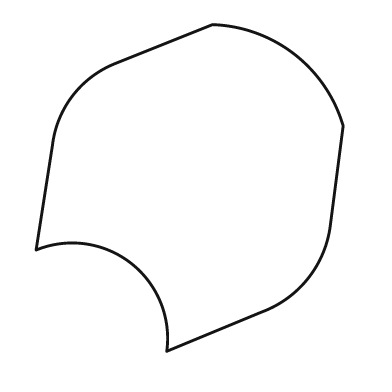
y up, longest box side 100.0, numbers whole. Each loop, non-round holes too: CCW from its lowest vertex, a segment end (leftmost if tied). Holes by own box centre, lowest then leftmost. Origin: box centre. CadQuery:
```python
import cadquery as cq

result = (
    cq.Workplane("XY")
    .moveTo(-7.0, -50.0)
    .lineTo(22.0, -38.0)
    .threePointArc((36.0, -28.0), (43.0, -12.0))
    .lineTo(47.0, 19.0)
    .threePointArc((32.0, 41.0), (7.0, 50.0))
    .lineTo(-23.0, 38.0)
    .threePointArc((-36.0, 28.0), (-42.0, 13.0))
    .lineTo(-47.0, -19.0)
    .threePointArc((-18.0, -23.0), (-7.0, -50.0))
    .close()
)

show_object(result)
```